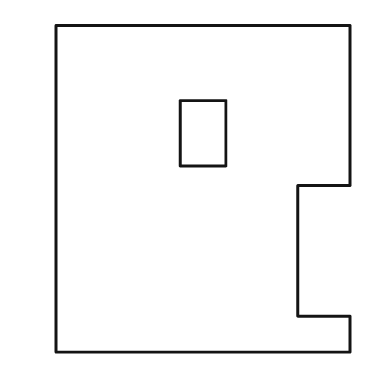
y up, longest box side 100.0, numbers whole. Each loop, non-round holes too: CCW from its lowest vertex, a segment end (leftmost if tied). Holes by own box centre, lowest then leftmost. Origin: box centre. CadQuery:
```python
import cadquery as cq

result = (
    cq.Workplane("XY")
    .moveTo(-45.0, -50.0)
    .lineTo(45.0, -50.0)
    .lineTo(45.0, -39.0)
    .lineTo(29.0, -39.0)
    .lineTo(29.0, 1.0)
    .lineTo(45.0, 1.0)
    .lineTo(45.0, 50.0)
    .lineTo(-45.0, 50.0)
    .close()
    .moveTo(-7.0, 7.0)
    .lineTo(7.0, 7.0)
    .lineTo(7.0, 27.0)
    .lineTo(-7.0, 27.0)
    .close()
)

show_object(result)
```